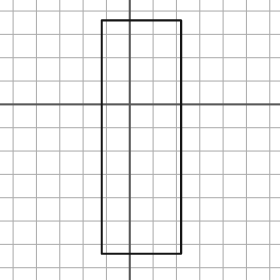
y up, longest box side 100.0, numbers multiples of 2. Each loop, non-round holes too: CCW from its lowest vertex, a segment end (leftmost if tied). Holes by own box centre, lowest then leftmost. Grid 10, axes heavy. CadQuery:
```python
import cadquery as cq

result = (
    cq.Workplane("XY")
    .moveTo(-12.0, -64.0)
    .lineTo(22.0, -64.0)
    .lineTo(22.0, 36.0)
    .lineTo(-12.0, 36.0)
    .close()
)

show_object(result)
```